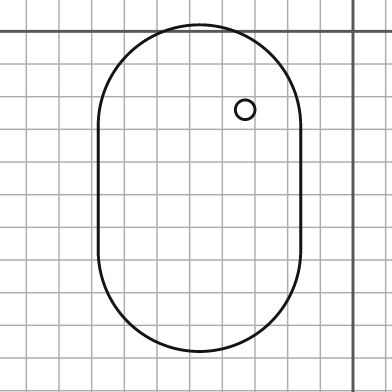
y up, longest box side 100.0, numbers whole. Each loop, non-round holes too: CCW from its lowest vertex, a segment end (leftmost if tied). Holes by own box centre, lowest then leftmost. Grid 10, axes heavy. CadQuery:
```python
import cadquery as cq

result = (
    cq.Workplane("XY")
    .moveTo(-78.0, -67.0)
    .threePointArc((-47.0, -98.0), (-16.0, -67.0))
    .lineTo(-16.0, -29.0)
    .threePointArc((-47.0, 2.0), (-78.0, -29.0))
    .close()
    .moveTo(-33.0, -24.0)
    .circle(3.0)
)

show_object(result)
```